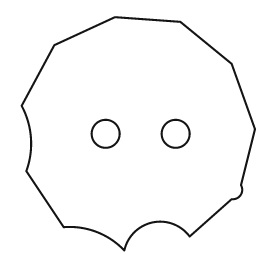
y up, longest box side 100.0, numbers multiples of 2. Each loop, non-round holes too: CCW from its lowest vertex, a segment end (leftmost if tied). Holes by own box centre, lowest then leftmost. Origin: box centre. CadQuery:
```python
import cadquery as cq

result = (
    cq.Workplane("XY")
    .moveTo(-6.0, -50.0)
    .threePointArc((6.0, -38.0), (22.0, -44.0))
    .lineTo(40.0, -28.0)
    .threePointArc((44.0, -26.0), (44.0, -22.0))
    .lineTo(50.0, 2.0)
    .lineTo(40.0, 30.0)
    .lineTo(18.0, 48.0)
    .lineTo(-10.0, 50.0)
    .lineTo(-36.0, 38.0)
    .lineTo(-50.0, 12.0)
    .threePointArc((-46.0, -2.0), (-48.0, -16.0))
    .lineTo(-32.0, -40.0)
    .threePointArc((-18.0, -42.0), (-6.0, -50.0))
    .close()
    .moveTo(-14.0, 0.0)
    .circle(6.0)
    .moveTo(16.0, 0.0)
    .circle(6.0)
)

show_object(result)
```